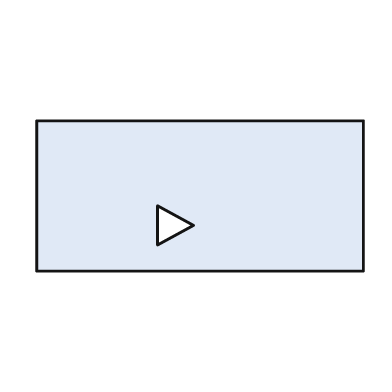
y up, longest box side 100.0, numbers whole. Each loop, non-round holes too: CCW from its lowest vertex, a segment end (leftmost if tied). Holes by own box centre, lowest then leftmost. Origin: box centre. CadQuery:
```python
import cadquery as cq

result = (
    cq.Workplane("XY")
    .moveTo(-50.0, -23.0)
    .lineTo(50.0, -23.0)
    .lineTo(50.0, 23.0)
    .lineTo(-50.0, 23.0)
    .close()
    .moveTo(-13.0, -15.0)
    .lineTo(-2.0, -9.0)
    .lineTo(-13.0, -3.0)
    .close()
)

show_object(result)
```